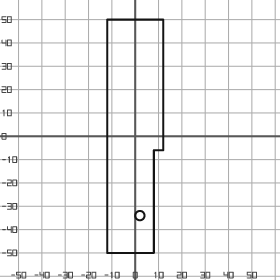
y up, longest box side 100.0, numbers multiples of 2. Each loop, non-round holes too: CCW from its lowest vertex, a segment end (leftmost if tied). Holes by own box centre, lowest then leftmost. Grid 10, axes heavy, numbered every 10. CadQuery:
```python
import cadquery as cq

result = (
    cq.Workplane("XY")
    .moveTo(-12.0, -50.0)
    .lineTo(8.0, -50.0)
    .lineTo(8.0, -6.0)
    .lineTo(12.0, -6.0)
    .lineTo(12.0, 50.0)
    .lineTo(-12.0, 50.0)
    .close()
    .moveTo(2.0, -34.0)
    .circle(2.0)
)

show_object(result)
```